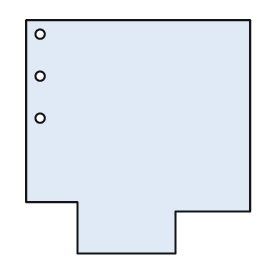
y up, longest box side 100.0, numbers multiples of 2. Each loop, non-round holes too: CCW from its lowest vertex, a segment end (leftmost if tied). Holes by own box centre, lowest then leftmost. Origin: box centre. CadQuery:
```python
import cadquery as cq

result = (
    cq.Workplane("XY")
    .moveTo(-26.0, -50.0)
    .lineTo(16.0, -50.0)
    .lineTo(16.0, -32.0)
    .lineTo(48.0, -32.0)
    .lineTo(48.0, 50.0)
    .lineTo(-48.0, 50.0)
    .lineTo(-48.0, -28.0)
    .lineTo(-26.0, -28.0)
    .close()
    .moveTo(-42.0, 8.0)
    .circle(2.0)
    .moveTo(-42.0, 26.0)
    .circle(2.0)
    .moveTo(-42.0, 44.0)
    .circle(2.0)
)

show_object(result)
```